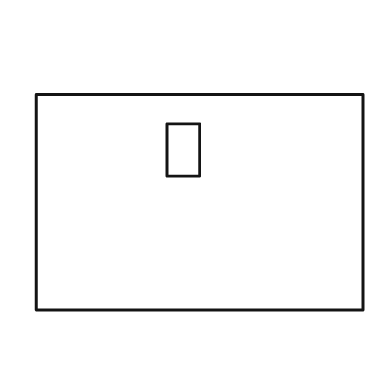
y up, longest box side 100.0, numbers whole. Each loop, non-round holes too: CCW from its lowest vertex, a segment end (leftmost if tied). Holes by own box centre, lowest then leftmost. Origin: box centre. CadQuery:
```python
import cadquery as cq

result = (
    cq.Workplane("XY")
    .moveTo(-50.0, -33.0)
    .lineTo(50.0, -33.0)
    .lineTo(50.0, 33.0)
    .lineTo(-50.0, 33.0)
    .close()
    .moveTo(-10.0, 8.0)
    .lineTo(0.0, 8.0)
    .lineTo(0.0, 24.0)
    .lineTo(-10.0, 24.0)
    .close()
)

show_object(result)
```